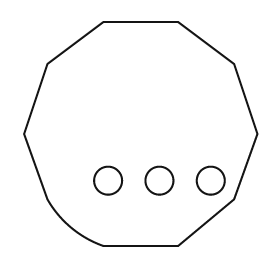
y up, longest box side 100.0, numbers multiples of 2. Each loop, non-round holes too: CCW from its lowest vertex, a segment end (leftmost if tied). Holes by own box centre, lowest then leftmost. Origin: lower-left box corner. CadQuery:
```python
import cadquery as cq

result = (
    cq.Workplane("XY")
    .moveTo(34.0, 0.0)
    .lineTo(66.0, 0.0)
    .lineTo(90.0, 20.0)
    .lineTo(100.0, 48.0)
    .lineTo(90.0, 78.0)
    .lineTo(66.0, 96.0)
    .lineTo(34.0, 96.0)
    .lineTo(10.0, 78.0)
    .lineTo(0.0, 48.0)
    .lineTo(10.0, 20.0)
    .threePointArc((20.0, 8.0), (34.0, 0.0))
    .close()
    .moveTo(36.0, 28.0)
    .circle(6.0)
    .moveTo(58.0, 28.0)
    .circle(6.0)
    .moveTo(80.0, 28.0)
    .circle(6.0)
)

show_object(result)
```